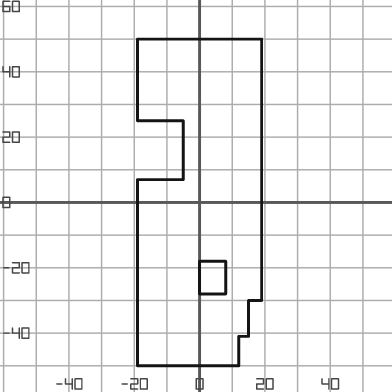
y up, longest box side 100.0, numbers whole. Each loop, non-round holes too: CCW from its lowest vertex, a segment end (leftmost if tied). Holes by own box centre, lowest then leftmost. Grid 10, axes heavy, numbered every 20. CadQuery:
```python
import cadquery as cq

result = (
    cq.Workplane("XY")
    .moveTo(-19.0, -50.0)
    .lineTo(12.0, -50.0)
    .lineTo(12.0, -41.0)
    .lineTo(15.0, -41.0)
    .lineTo(15.0, -30.0)
    .lineTo(19.0, -30.0)
    .lineTo(19.0, 50.0)
    .lineTo(-19.0, 50.0)
    .lineTo(-19.0, 25.0)
    .lineTo(-5.0, 25.0)
    .lineTo(-5.0, 7.0)
    .lineTo(-19.0, 7.0)
    .close()
    .moveTo(0.0, -28.0)
    .lineTo(8.0, -28.0)
    .lineTo(8.0, -18.0)
    .lineTo(0.0, -18.0)
    .close()
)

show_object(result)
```